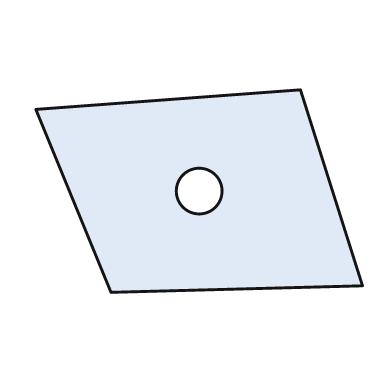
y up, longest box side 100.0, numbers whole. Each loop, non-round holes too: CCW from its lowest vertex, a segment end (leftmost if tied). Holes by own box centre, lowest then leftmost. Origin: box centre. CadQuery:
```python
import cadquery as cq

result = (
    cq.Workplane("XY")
    .moveTo(-27.0, -31.0)
    .lineTo(50.0, -29.0)
    .lineTo(31.0, 31.0)
    .lineTo(-50.0, 25.0)
    .close()
    .moveTo(0.0, 0.0)
    .circle(7.0)
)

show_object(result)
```